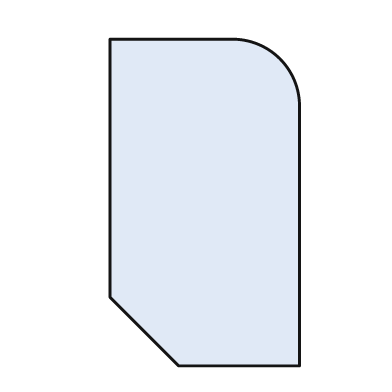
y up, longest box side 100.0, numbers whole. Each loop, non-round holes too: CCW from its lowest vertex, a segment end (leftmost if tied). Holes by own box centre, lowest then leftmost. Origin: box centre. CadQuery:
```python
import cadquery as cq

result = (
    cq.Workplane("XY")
    .moveTo(-8.0, -50.0)
    .lineTo(29.0, -50.0)
    .lineTo(29.0, 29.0)
    .threePointArc((23.0, 44.0), (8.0, 50.0))
    .lineTo(-29.0, 50.0)
    .lineTo(-29.0, -29.0)
    .close()
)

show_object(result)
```